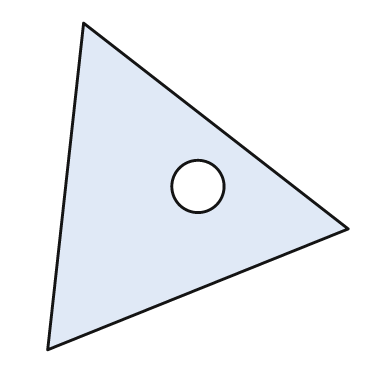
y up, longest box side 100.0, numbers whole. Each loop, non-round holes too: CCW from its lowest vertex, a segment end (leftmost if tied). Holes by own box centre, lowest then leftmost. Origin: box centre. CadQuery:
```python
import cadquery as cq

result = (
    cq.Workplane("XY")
    .moveTo(-46.0, -50.0)
    .lineTo(46.0, -13.0)
    .lineTo(-35.0, 50.0)
    .close()
    .moveTo(0.0, 0.0)
    .circle(8.0)
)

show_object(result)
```